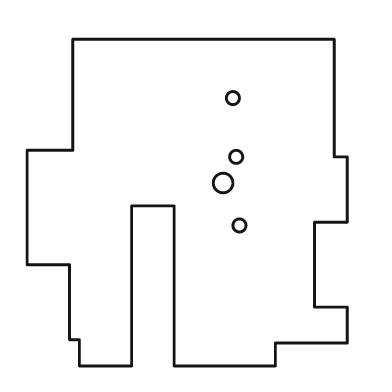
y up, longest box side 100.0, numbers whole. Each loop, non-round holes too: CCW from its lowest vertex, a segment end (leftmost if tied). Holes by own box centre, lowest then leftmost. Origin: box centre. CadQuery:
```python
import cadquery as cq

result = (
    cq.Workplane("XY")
    .moveTo(-33.0, -50.0)
    .lineTo(-17.0, -50.0)
    .lineTo(-17.0, -1.0)
    .lineTo(-4.0, -1.0)
    .lineTo(-4.0, -50.0)
    .lineTo(27.0, -50.0)
    .lineTo(27.0, -43.0)
    .lineTo(49.0, -43.0)
    .lineTo(49.0, -32.0)
    .lineTo(39.0, -32.0)
    .lineTo(39.0, -6.0)
    .lineTo(49.0, -6.0)
    .lineTo(49.0, 14.0)
    .lineTo(45.0, 14.0)
    .lineTo(45.0, 50.0)
    .lineTo(-35.0, 50.0)
    .lineTo(-35.0, 16.0)
    .lineTo(-49.0, 16.0)
    .lineTo(-49.0, -19.0)
    .lineTo(-36.0, -19.0)
    .lineTo(-36.0, -42.0)
    .lineTo(-33.0, -42.0)
    .close()
    .moveTo(16.0, -7.0)
    .circle(2.0)
    .moveTo(11.0, 6.0)
    .circle(3.0)
    .moveTo(15.0, 14.0)
    .circle(2.0)
    .moveTo(14.0, 32.0)
    .circle(2.0)
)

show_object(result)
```